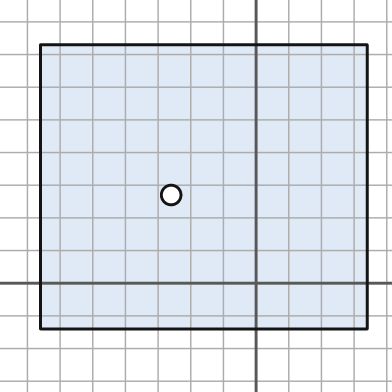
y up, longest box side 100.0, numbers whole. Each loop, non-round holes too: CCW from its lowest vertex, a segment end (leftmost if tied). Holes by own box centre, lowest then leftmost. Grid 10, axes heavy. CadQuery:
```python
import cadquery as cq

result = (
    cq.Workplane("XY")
    .moveTo(-66.0, -14.0)
    .lineTo(34.0, -14.0)
    .lineTo(34.0, 73.0)
    .lineTo(-66.0, 73.0)
    .close()
    .moveTo(-26.0, 27.0)
    .circle(3.0)
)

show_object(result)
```